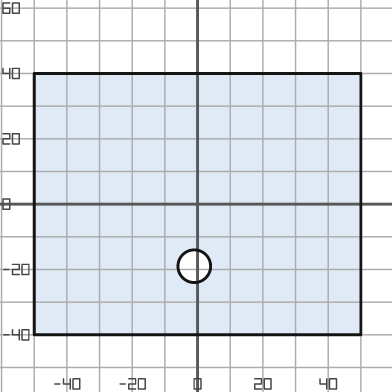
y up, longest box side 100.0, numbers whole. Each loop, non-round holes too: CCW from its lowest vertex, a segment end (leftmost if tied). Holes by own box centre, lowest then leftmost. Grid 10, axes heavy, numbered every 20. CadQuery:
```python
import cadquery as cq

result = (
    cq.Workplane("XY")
    .moveTo(-50.0, -40.0)
    .lineTo(50.0, -40.0)
    .lineTo(50.0, 40.0)
    .lineTo(-50.0, 40.0)
    .close()
    .moveTo(-1.0, -19.0)
    .circle(5.0)
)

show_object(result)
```